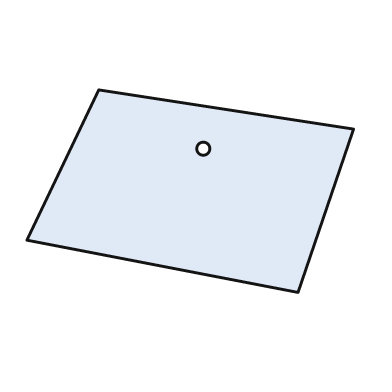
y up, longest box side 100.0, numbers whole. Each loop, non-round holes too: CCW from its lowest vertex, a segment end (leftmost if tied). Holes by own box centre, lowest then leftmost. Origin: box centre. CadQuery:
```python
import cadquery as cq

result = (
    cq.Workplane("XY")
    .moveTo(33.0, -31.0)
    .lineTo(50.0, 19.0)
    .lineTo(-28.0, 31.0)
    .lineTo(-50.0, -15.0)
    .close()
    .moveTo(4.0, 13.0)
    .circle(2.0)
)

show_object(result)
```